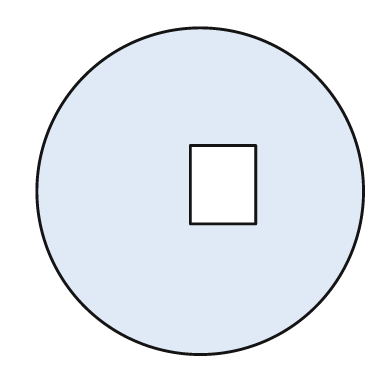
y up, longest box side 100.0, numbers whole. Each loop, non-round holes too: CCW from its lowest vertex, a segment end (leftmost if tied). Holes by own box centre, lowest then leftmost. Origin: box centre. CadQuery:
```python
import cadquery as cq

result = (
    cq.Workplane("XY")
    .moveTo(0.0, 0.0)
    .circle(50.0)
    .moveTo(-3.0, -10.0)
    .lineTo(17.0, -10.0)
    .lineTo(17.0, 14.0)
    .lineTo(-3.0, 14.0)
    .close()
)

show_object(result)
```